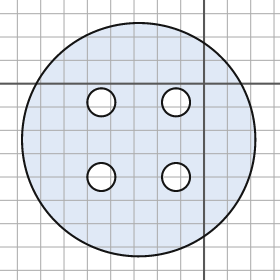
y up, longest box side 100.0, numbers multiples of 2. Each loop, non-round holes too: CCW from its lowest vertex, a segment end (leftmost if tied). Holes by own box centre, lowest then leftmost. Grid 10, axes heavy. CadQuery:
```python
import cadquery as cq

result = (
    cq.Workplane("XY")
    .moveTo(-28.0, -24.0)
    .circle(50.0)
    .moveTo(-44.0, -40.0)
    .circle(6.0)
    .moveTo(-12.0, -40.0)
    .circle(6.0)
    .moveTo(-44.0, -8.0)
    .circle(6.0)
    .moveTo(-12.0, -8.0)
    .circle(6.0)
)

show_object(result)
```